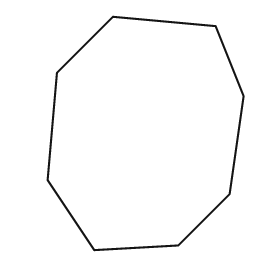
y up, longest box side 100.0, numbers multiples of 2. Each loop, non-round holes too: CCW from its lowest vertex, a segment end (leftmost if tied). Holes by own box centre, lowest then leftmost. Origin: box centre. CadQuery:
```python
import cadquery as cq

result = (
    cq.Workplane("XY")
    .moveTo(-22.0, -50.0)
    .lineTo(14.0, -48.0)
    .lineTo(36.0, -26.0)
    .lineTo(42.0, 16.0)
    .lineTo(30.0, 46.0)
    .lineTo(-14.0, 50.0)
    .lineTo(-38.0, 26.0)
    .lineTo(-42.0, -20.0)
    .close()
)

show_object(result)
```